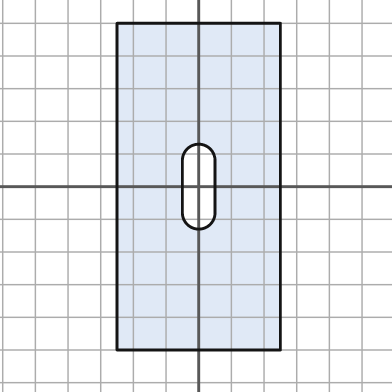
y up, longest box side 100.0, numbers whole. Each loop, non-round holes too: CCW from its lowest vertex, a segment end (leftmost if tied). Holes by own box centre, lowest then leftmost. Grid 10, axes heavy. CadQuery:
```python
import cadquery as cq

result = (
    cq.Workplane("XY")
    .moveTo(-25.0, -50.0)
    .lineTo(25.0, -50.0)
    .lineTo(25.0, 50.0)
    .lineTo(-25.0, 50.0)
    .close()
    .moveTo(-5.0, -8.0)
    .threePointArc((0.0, -13.0), (5.0, -8.0))
    .lineTo(5.0, 8.0)
    .threePointArc((0.0, 13.0), (-5.0, 8.0))
    .close()
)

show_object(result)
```